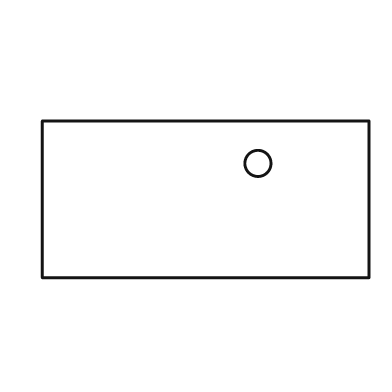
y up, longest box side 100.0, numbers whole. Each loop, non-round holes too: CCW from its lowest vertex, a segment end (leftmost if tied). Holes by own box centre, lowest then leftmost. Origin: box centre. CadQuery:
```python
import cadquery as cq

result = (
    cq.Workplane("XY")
    .moveTo(-50.0, -24.0)
    .lineTo(50.0, -24.0)
    .lineTo(50.0, 24.0)
    .lineTo(-50.0, 24.0)
    .close()
    .moveTo(16.0, 11.0)
    .circle(4.0)
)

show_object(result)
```